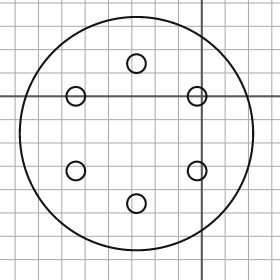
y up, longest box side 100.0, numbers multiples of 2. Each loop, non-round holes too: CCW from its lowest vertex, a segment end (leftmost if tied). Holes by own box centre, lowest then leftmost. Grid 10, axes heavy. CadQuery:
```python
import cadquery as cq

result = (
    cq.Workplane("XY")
    .moveTo(-28.0, -16.0)
    .circle(50.0)
    .moveTo(-28.0, -46.0)
    .circle(4.0)
    .moveTo(-54.0, -32.0)
    .circle(4.0)
    .moveTo(-2.0, -32.0)
    .circle(4.0)
    .moveTo(-54.0, 0.0)
    .circle(4.0)
    .moveTo(-2.0, 0.0)
    .circle(4.0)
    .moveTo(-28.0, 14.0)
    .circle(4.0)
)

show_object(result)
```